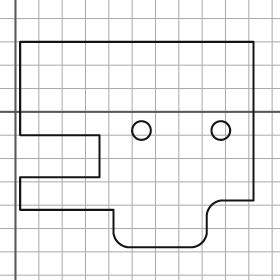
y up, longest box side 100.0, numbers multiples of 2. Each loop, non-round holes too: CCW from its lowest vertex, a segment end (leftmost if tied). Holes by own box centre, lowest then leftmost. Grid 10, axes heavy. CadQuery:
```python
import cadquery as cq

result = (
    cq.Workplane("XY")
    .moveTo(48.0, -58.0)
    .lineTo(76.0, -58.0)
    .threePointArc((80.0, -56.0), (82.0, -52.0))
    .lineTo(82.0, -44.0)
    .threePointArc((84.0, -40.0), (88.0, -38.0))
    .lineTo(102.0, -38.0)
    .lineTo(102.0, 30.0)
    .lineTo(2.0, 30.0)
    .lineTo(2.0, -10.0)
    .lineTo(36.0, -10.0)
    .lineTo(36.0, -28.0)
    .lineTo(2.0, -28.0)
    .lineTo(2.0, -42.0)
    .lineTo(42.0, -42.0)
    .lineTo(42.0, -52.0)
    .threePointArc((44.0, -56.0), (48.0, -58.0))
    .close()
    .moveTo(54.0, -8.0)
    .circle(4.0)
    .moveTo(88.0, -8.0)
    .circle(4.0)
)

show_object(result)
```